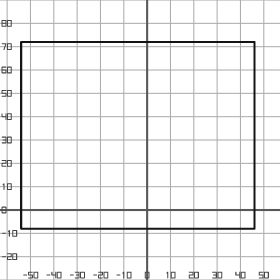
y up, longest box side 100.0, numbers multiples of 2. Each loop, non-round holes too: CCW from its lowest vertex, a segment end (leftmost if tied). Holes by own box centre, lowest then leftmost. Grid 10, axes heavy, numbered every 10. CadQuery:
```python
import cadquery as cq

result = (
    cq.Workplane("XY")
    .moveTo(-54.0, -8.0)
    .lineTo(46.0, -8.0)
    .lineTo(46.0, 72.0)
    .lineTo(-54.0, 72.0)
    .close()
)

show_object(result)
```